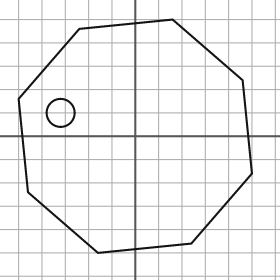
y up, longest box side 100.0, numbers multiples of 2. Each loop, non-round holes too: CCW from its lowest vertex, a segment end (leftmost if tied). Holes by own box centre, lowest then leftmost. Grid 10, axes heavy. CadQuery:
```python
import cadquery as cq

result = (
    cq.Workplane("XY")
    .moveTo(-16.0, -50.0)
    .lineTo(24.0, -46.0)
    .lineTo(50.0, -16.0)
    .lineTo(46.0, 24.0)
    .lineTo(16.0, 50.0)
    .lineTo(-24.0, 46.0)
    .lineTo(-50.0, 16.0)
    .lineTo(-46.0, -24.0)
    .close()
    .moveTo(-32.0, 10.0)
    .circle(6.0)
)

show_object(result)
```